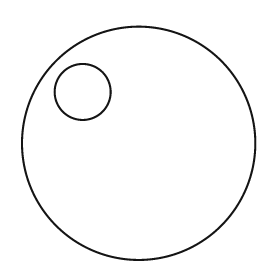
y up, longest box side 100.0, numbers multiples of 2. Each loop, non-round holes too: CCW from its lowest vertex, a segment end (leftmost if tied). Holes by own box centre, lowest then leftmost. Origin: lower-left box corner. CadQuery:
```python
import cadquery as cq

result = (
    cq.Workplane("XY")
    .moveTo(50.0, 50.0)
    .circle(50.0)
    .moveTo(26.0, 72.0)
    .circle(12.0)
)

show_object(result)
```